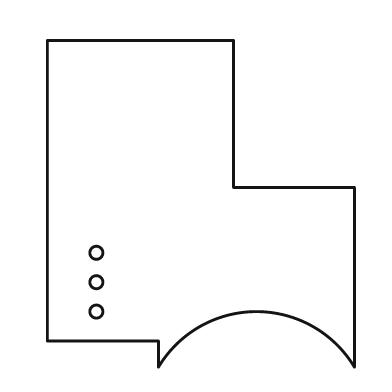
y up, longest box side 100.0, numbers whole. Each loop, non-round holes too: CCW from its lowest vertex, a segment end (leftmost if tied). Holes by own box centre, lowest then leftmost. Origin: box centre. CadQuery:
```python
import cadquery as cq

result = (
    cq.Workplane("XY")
    .moveTo(-13.0, -50.0)
    .threePointArc((17.0, -33.0), (47.0, -50.0))
    .lineTo(47.0, 5.0)
    .lineTo(10.0, 5.0)
    .lineTo(10.0, 50.0)
    .lineTo(-47.0, 50.0)
    .lineTo(-47.0, -42.0)
    .lineTo(-13.0, -42.0)
    .close()
    .moveTo(-32.0, -33.0)
    .circle(2.0)
    .moveTo(-32.0, -24.0)
    .circle(2.0)
    .moveTo(-32.0, -15.0)
    .circle(2.0)
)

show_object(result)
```